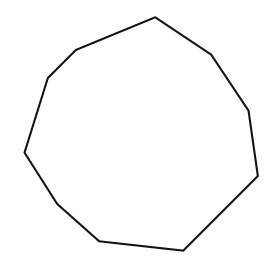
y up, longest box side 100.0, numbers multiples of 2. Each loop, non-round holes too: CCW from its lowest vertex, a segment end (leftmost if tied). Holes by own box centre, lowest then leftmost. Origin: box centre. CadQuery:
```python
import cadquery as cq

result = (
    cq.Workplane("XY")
    .moveTo(18.0, -50.0)
    .lineTo(50.0, -18.0)
    .lineTo(46.0, 10.0)
    .lineTo(30.0, 34.0)
    .lineTo(6.0, 50.0)
    .lineTo(-28.0, 36.0)
    .lineTo(-40.0, 24.0)
    .lineTo(-50.0, -8.0)
    .lineTo(-36.0, -30.0)
    .lineTo(-18.0, -46.0)
    .close()
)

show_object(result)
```